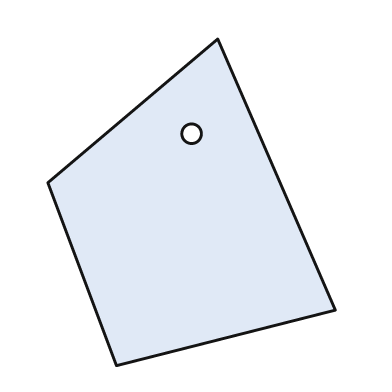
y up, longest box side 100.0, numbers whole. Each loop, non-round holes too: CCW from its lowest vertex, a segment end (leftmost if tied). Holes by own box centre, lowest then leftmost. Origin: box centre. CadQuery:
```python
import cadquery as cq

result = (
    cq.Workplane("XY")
    .moveTo(-23.0, -50.0)
    .lineTo(44.0, -33.0)
    .lineTo(8.0, 50.0)
    .lineTo(-44.0, 6.0)
    .close()
    .moveTo(0.0, 21.0)
    .circle(3.0)
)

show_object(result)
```